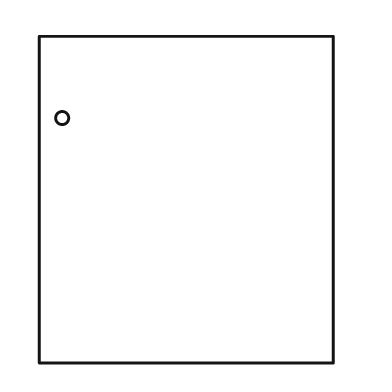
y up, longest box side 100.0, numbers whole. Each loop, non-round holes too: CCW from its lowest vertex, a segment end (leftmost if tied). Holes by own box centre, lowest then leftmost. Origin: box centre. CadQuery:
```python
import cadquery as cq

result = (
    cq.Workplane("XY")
    .moveTo(-45.0, -50.0)
    .lineTo(45.0, -50.0)
    .lineTo(45.0, 50.0)
    .lineTo(-45.0, 50.0)
    .close()
    .moveTo(-38.0, 25.0)
    .circle(2.0)
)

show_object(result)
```